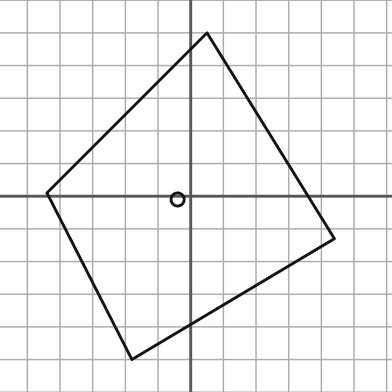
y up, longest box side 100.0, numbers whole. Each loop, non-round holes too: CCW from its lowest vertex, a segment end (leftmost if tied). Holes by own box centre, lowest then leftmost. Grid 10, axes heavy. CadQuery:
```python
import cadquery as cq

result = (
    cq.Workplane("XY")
    .moveTo(-18.0, -50.0)
    .lineTo(44.0, -13.0)
    .lineTo(5.0, 50.0)
    .lineTo(-44.0, 1.0)
    .close()
    .moveTo(-4.0, -1.0)
    .circle(2.0)
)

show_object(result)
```